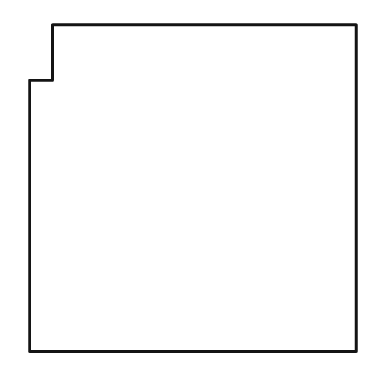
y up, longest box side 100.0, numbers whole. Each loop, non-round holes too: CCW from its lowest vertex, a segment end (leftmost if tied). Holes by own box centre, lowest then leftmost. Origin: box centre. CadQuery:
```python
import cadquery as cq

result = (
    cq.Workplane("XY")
    .moveTo(-50.0, -50.0)
    .lineTo(50.0, -50.0)
    .lineTo(50.0, 50.0)
    .lineTo(-43.0, 50.0)
    .lineTo(-43.0, 33.0)
    .lineTo(-50.0, 33.0)
    .close()
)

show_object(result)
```